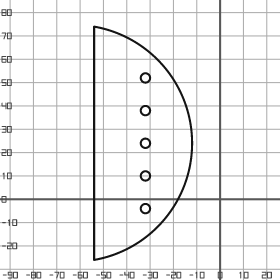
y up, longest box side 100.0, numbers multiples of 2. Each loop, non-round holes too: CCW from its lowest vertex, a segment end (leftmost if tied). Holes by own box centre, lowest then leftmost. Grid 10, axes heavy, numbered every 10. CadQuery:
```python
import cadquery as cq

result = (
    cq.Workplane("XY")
    .moveTo(-54.0, -26.0)
    .threePointArc((-12.0, 24.0), (-54.0, 74.0))
    .close()
    .moveTo(-32.0, -4.0)
    .circle(2.0)
    .moveTo(-32.0, 10.0)
    .circle(2.0)
    .moveTo(-32.0, 24.0)
    .circle(2.0)
    .moveTo(-32.0, 38.0)
    .circle(2.0)
    .moveTo(-32.0, 52.0)
    .circle(2.0)
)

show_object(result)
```